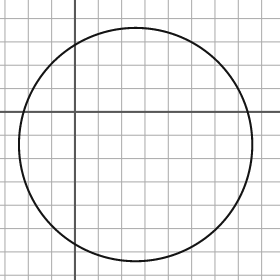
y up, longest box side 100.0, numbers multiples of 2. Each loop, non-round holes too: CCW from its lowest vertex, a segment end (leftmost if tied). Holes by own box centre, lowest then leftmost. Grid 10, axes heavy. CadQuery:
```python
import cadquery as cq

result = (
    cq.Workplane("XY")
    .moveTo(26.0, -14.0)
    .circle(50.0)
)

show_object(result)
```